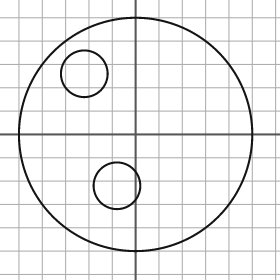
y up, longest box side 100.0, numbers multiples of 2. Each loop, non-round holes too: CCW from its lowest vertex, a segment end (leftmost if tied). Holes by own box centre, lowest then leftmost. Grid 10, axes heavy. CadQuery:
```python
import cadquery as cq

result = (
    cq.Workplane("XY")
    .moveTo(0.0, 0.0)
    .circle(50.0)
    .moveTo(-8.0, -22.0)
    .circle(10.0)
    .moveTo(-22.0, 26.0)
    .circle(10.0)
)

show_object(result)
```